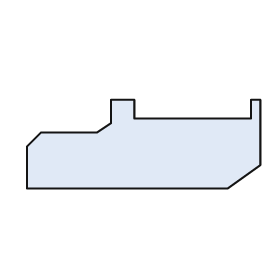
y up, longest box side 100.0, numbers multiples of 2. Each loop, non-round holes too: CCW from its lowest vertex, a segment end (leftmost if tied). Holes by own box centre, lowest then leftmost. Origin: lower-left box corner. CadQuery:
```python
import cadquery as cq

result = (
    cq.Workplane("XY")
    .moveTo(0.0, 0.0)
    .lineTo(86.0, 0.0)
    .lineTo(100.0, 10.0)
    .lineTo(100.0, 38.0)
    .lineTo(96.0, 38.0)
    .lineTo(96.0, 30.0)
    .lineTo(46.0, 30.0)
    .lineTo(46.0, 38.0)
    .lineTo(36.0, 38.0)
    .lineTo(36.0, 28.0)
    .lineTo(30.0, 24.0)
    .lineTo(6.0, 24.0)
    .lineTo(0.0, 18.0)
    .close()
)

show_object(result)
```